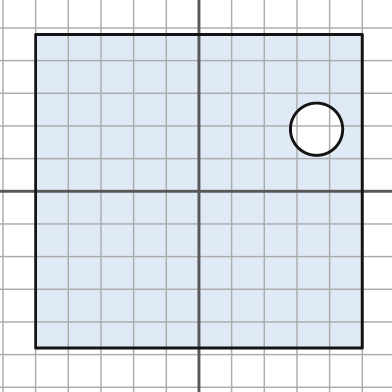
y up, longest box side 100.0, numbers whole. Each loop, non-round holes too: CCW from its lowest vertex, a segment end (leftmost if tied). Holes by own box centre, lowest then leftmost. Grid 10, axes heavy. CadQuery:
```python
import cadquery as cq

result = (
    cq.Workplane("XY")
    .moveTo(-50.0, -48.0)
    .lineTo(50.0, -48.0)
    .lineTo(50.0, 48.0)
    .lineTo(-50.0, 48.0)
    .close()
    .moveTo(36.0, 19.0)
    .circle(8.0)
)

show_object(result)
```